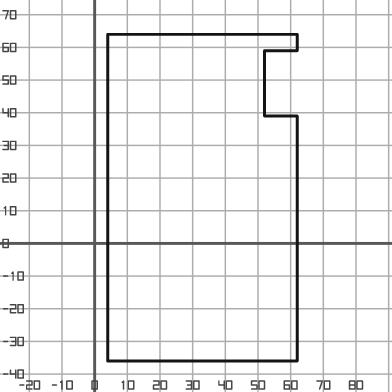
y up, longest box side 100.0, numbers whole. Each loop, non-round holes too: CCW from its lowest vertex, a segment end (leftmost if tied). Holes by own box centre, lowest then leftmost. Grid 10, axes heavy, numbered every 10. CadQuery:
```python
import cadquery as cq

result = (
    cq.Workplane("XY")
    .moveTo(4.0, -36.0)
    .lineTo(62.0, -36.0)
    .lineTo(62.0, 39.0)
    .lineTo(52.0, 39.0)
    .lineTo(52.0, 59.0)
    .lineTo(62.0, 59.0)
    .lineTo(62.0, 64.0)
    .lineTo(4.0, 64.0)
    .close()
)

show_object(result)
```